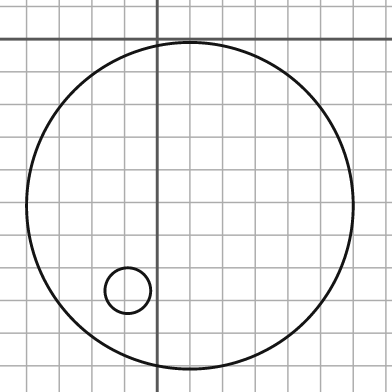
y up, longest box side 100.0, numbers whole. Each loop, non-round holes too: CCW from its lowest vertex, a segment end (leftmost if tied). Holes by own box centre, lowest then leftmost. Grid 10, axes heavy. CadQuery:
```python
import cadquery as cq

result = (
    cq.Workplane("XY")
    .moveTo(10.0, -51.0)
    .circle(50.0)
    .moveTo(-9.0, -77.0)
    .circle(7.0)
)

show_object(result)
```